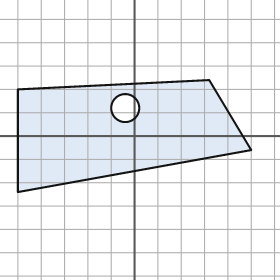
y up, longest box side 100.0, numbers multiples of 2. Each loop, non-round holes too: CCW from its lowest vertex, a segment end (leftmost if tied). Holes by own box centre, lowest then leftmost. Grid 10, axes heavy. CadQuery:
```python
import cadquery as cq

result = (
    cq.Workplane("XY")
    .moveTo(-50.0, -24.0)
    .lineTo(50.0, -6.0)
    .lineTo(32.0, 24.0)
    .lineTo(-50.0, 20.0)
    .close()
    .moveTo(-4.0, 12.0)
    .circle(6.0)
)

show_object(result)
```